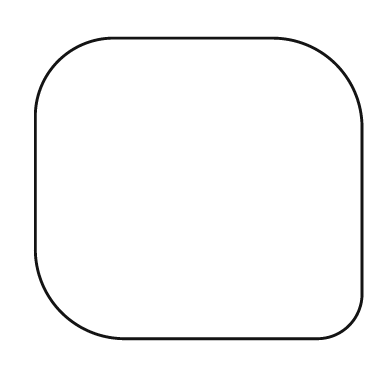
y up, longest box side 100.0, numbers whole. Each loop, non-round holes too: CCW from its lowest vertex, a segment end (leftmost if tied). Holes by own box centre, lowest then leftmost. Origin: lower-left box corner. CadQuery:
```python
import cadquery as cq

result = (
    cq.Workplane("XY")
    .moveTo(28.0, 0.0)
    .lineTo(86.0, 0.0)
    .threePointArc((96.0, 4.0), (100.0, 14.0))
    .lineTo(100.0, 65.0)
    .threePointArc((92.0, 84.0), (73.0, 92.0))
    .lineTo(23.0, 92.0)
    .threePointArc((7.0, 85.0), (0.0, 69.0))
    .lineTo(0.0, 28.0)
    .threePointArc((8.0, 8.0), (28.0, 0.0))
    .close()
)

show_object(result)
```